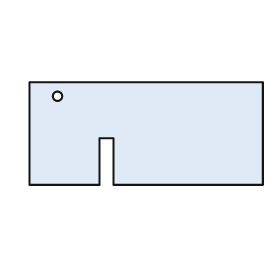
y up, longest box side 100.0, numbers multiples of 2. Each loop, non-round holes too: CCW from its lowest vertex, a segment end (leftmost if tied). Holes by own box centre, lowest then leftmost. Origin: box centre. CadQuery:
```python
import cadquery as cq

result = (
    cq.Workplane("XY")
    .moveTo(-50.0, -22.0)
    .lineTo(-20.0, -22.0)
    .lineTo(-20.0, -2.0)
    .lineTo(-14.0, -2.0)
    .lineTo(-14.0, -22.0)
    .lineTo(50.0, -22.0)
    .lineTo(50.0, 22.0)
    .lineTo(-50.0, 22.0)
    .close()
    .moveTo(-38.0, 16.0)
    .circle(2.0)
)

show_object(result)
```